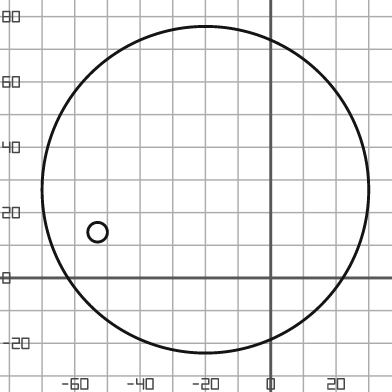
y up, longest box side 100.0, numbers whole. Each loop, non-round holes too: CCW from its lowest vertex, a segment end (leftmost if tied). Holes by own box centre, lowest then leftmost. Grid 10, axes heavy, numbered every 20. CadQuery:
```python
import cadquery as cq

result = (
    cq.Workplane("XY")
    .moveTo(-20.0, 27.0)
    .circle(50.0)
    .moveTo(-53.0, 14.0)
    .circle(3.0)
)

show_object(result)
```